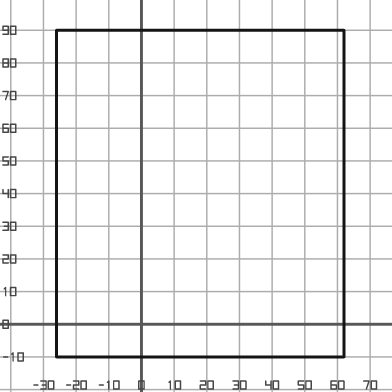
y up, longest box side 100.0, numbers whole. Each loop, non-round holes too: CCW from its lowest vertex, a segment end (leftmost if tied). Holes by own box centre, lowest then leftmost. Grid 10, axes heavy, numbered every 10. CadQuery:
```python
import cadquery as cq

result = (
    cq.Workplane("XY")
    .moveTo(-26.0, -10.0)
    .lineTo(62.0, -10.0)
    .lineTo(62.0, 90.0)
    .lineTo(-26.0, 90.0)
    .close()
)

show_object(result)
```